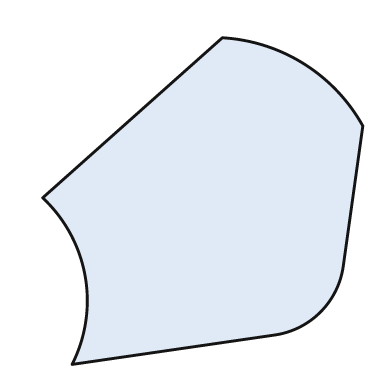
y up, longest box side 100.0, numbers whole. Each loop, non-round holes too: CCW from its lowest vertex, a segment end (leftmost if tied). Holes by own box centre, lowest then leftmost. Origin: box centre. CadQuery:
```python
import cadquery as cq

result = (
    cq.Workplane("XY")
    .moveTo(-40.0, -50.0)
    .lineTo(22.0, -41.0)
    .threePointArc((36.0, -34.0), (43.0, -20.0))
    .lineTo(49.0, 23.0)
    .threePointArc((31.0, 42.0), (6.0, 50.0))
    .lineTo(-49.0, 1.0)
    .threePointArc((-36.0, -23.0), (-40.0, -50.0))
    .close()
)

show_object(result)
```